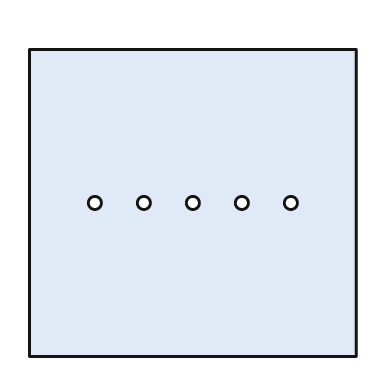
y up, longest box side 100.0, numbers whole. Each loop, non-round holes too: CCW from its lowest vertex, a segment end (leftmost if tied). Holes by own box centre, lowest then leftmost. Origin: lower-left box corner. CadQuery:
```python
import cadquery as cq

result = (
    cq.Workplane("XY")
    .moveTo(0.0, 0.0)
    .lineTo(100.0, 0.0)
    .lineTo(100.0, 94.0)
    .lineTo(0.0, 94.0)
    .close()
    .moveTo(20.0, 47.0)
    .circle(2.0)
    .moveTo(35.0, 47.0)
    .circle(2.0)
    .moveTo(50.0, 47.0)
    .circle(2.0)
    .moveTo(65.0, 47.0)
    .circle(2.0)
    .moveTo(80.0, 47.0)
    .circle(2.0)
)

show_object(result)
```